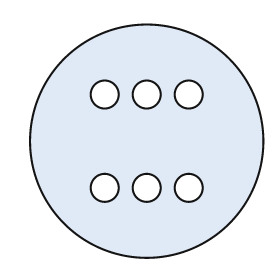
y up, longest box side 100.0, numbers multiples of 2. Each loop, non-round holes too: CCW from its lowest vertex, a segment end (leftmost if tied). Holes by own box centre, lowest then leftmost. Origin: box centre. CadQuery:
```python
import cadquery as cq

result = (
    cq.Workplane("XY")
    .moveTo(0.0, 0.0)
    .circle(50.0)
    .moveTo(-18.0, -20.0)
    .circle(6.0)
    .moveTo(0.0, -20.0)
    .circle(6.0)
    .moveTo(18.0, -20.0)
    .circle(6.0)
    .moveTo(-18.0, 20.0)
    .circle(6.0)
    .moveTo(0.0, 20.0)
    .circle(6.0)
    .moveTo(18.0, 20.0)
    .circle(6.0)
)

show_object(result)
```